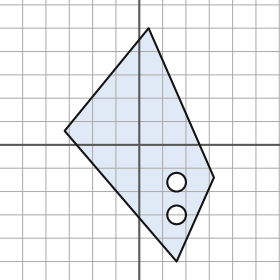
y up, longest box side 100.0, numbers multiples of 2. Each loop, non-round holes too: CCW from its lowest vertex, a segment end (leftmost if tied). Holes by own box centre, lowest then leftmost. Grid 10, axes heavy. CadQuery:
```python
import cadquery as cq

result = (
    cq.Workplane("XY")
    .moveTo(16.0, -50.0)
    .lineTo(32.0, -14.0)
    .lineTo(4.0, 50.0)
    .lineTo(-32.0, 6.0)
    .close()
    .moveTo(16.0, -30.0)
    .circle(4.0)
    .moveTo(16.0, -16.0)
    .circle(4.0)
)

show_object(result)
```